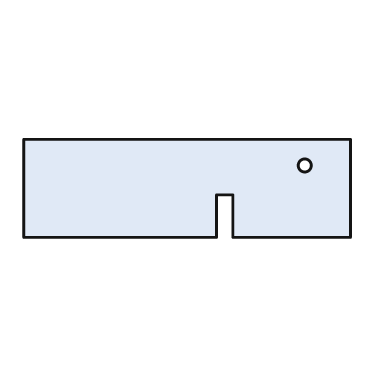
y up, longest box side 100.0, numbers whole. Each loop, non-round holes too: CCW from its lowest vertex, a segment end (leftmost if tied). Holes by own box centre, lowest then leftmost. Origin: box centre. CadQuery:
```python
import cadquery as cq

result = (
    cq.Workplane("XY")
    .moveTo(-50.0, -15.0)
    .lineTo(9.0, -15.0)
    .lineTo(9.0, -2.0)
    .lineTo(14.0, -2.0)
    .lineTo(14.0, -15.0)
    .lineTo(50.0, -15.0)
    .lineTo(50.0, 15.0)
    .lineTo(-50.0, 15.0)
    .close()
    .moveTo(36.0, 7.0)
    .circle(2.0)
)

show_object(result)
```